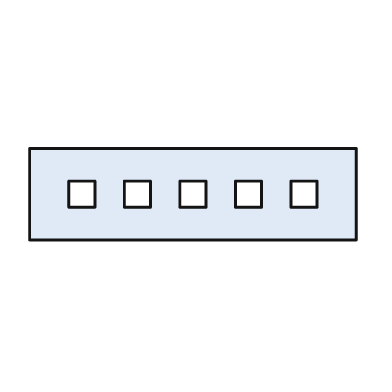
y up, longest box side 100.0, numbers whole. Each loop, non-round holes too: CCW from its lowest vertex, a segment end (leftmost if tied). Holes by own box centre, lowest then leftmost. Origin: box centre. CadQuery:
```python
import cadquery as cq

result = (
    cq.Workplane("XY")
    .moveTo(-50.0, -14.0)
    .lineTo(50.0, -14.0)
    .lineTo(50.0, 14.0)
    .lineTo(-50.0, 14.0)
    .close()
    .moveTo(-38.0, -4.0)
    .lineTo(-30.0, -4.0)
    .lineTo(-30.0, 4.0)
    .lineTo(-38.0, 4.0)
    .close()
    .moveTo(-21.0, -4.0)
    .lineTo(-13.0, -4.0)
    .lineTo(-13.0, 4.0)
    .lineTo(-21.0, 4.0)
    .close()
    .moveTo(-4.0, -4.0)
    .lineTo(4.0, -4.0)
    .lineTo(4.0, 4.0)
    .lineTo(-4.0, 4.0)
    .close()
    .moveTo(13.0, -4.0)
    .lineTo(21.0, -4.0)
    .lineTo(21.0, 4.0)
    .lineTo(13.0, 4.0)
    .close()
    .moveTo(30.0, -4.0)
    .lineTo(38.0, -4.0)
    .lineTo(38.0, 4.0)
    .lineTo(30.0, 4.0)
    .close()
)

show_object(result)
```